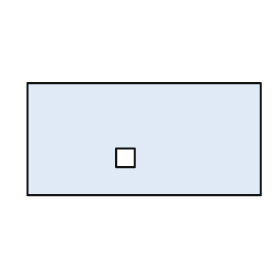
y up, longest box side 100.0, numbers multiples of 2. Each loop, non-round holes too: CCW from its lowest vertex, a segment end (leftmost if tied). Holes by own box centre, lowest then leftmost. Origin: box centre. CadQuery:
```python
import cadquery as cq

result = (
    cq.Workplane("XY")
    .moveTo(-50.0, -24.0)
    .lineTo(50.0, -24.0)
    .lineTo(50.0, 24.0)
    .lineTo(-50.0, 24.0)
    .close()
    .moveTo(-12.0, -12.0)
    .lineTo(-4.0, -12.0)
    .lineTo(-4.0, -4.0)
    .lineTo(-12.0, -4.0)
    .close()
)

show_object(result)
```